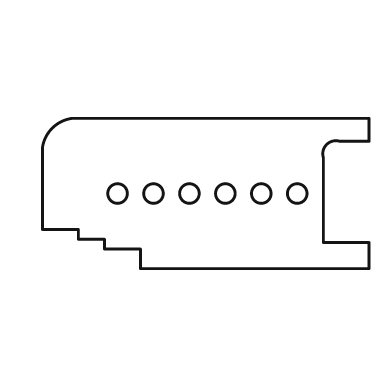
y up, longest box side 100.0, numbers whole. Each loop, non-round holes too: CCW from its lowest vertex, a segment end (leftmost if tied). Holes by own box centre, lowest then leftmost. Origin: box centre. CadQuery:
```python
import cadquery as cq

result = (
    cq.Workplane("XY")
    .moveTo(-20.0, -23.0)
    .lineTo(50.0, -23.0)
    .lineTo(50.0, -15.0)
    .lineTo(36.0, -15.0)
    .lineTo(36.0, 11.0)
    .threePointArc((37.0, 15.0), (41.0, 16.0))
    .lineTo(50.0, 16.0)
    .lineTo(50.0, 23.0)
    .lineTo(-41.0, 23.0)
    .threePointArc((-47.0, 20.0), (-50.0, 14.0))
    .lineTo(-50.0, -11.0)
    .lineTo(-39.0, -11.0)
    .lineTo(-39.0, -14.0)
    .lineTo(-31.0, -14.0)
    .lineTo(-31.0, -17.0)
    .lineTo(-20.0, -17.0)
    .close()
    .moveTo(-27.0, 0.0)
    .circle(3.0)
    .moveTo(-16.0, 0.0)
    .circle(3.0)
    .moveTo(-5.0, 0.0)
    .circle(3.0)
    .moveTo(6.0, 0.0)
    .circle(3.0)
    .moveTo(17.0, 0.0)
    .circle(3.0)
    .moveTo(28.0, 0.0)
    .circle(3.0)
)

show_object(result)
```